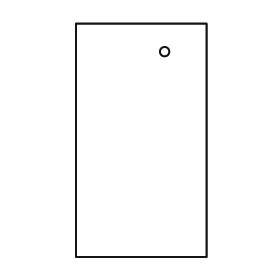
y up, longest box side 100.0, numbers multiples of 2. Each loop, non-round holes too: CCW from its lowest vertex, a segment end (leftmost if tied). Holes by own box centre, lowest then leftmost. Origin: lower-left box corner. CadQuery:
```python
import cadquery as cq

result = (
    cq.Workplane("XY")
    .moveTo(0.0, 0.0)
    .lineTo(56.0, 0.0)
    .lineTo(56.0, 100.0)
    .lineTo(0.0, 100.0)
    .close()
    .moveTo(38.0, 88.0)
    .circle(2.0)
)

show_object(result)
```